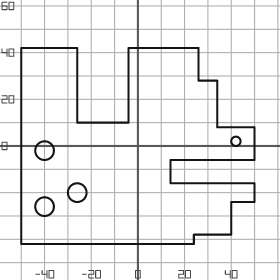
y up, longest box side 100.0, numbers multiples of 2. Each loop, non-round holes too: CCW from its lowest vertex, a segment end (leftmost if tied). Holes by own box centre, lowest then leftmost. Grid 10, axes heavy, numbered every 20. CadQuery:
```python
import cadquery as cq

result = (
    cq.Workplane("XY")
    .moveTo(-50.0, -42.0)
    .lineTo(24.0, -42.0)
    .lineTo(24.0, -38.0)
    .lineTo(40.0, -38.0)
    .lineTo(40.0, -24.0)
    .lineTo(50.0, -24.0)
    .lineTo(50.0, -16.0)
    .lineTo(14.0, -16.0)
    .lineTo(14.0, -6.0)
    .lineTo(50.0, -6.0)
    .lineTo(50.0, 8.0)
    .lineTo(34.0, 8.0)
    .lineTo(34.0, 28.0)
    .lineTo(26.0, 28.0)
    .lineTo(26.0, 42.0)
    .lineTo(-4.0, 42.0)
    .lineTo(-4.0, 10.0)
    .lineTo(-26.0, 10.0)
    .lineTo(-26.0, 42.0)
    .lineTo(-50.0, 42.0)
    .close()
    .moveTo(-40.0, -26.0)
    .circle(4.0)
    .moveTo(-26.0, -20.0)
    .circle(4.0)
    .moveTo(-40.0, -2.0)
    .circle(4.0)
    .moveTo(42.0, 2.0)
    .circle(2.0)
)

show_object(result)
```